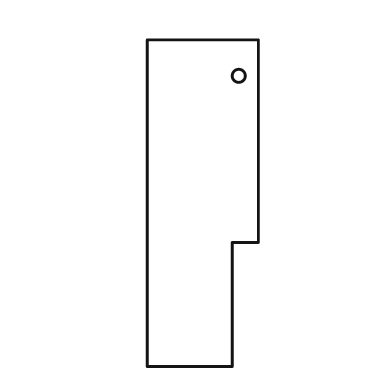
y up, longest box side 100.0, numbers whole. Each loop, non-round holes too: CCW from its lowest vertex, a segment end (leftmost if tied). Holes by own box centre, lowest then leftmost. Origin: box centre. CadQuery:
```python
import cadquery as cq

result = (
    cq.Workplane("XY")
    .moveTo(-17.0, -50.0)
    .lineTo(9.0, -50.0)
    .lineTo(9.0, -12.0)
    .lineTo(17.0, -12.0)
    .lineTo(17.0, 50.0)
    .lineTo(-17.0, 50.0)
    .close()
    .moveTo(11.0, 39.0)
    .circle(2.0)
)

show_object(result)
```